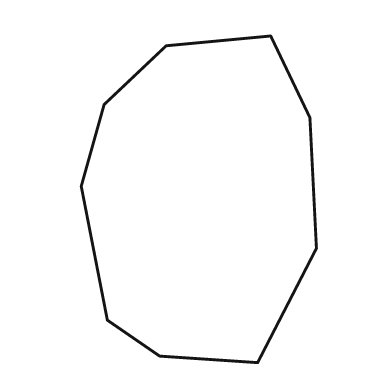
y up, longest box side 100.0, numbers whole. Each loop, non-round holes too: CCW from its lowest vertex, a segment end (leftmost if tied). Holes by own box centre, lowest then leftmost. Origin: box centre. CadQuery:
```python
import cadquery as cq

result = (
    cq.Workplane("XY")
    .moveTo(18.0, -50.0)
    .lineTo(36.0, -15.0)
    .lineTo(34.0, 25.0)
    .lineTo(22.0, 50.0)
    .lineTo(-10.0, 47.0)
    .lineTo(-29.0, 29.0)
    .lineTo(-36.0, 4.0)
    .lineTo(-28.0, -37.0)
    .lineTo(-12.0, -48.0)
    .close()
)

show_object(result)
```